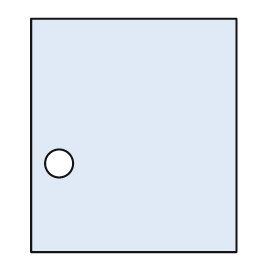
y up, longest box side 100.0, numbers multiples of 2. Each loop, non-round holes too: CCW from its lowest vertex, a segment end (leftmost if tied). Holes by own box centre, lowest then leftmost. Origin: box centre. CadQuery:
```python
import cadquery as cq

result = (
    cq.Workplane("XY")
    .moveTo(-44.0, -50.0)
    .lineTo(44.0, -50.0)
    .lineTo(44.0, 50.0)
    .lineTo(-44.0, 50.0)
    .close()
    .moveTo(-32.0, -12.0)
    .circle(6.0)
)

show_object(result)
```